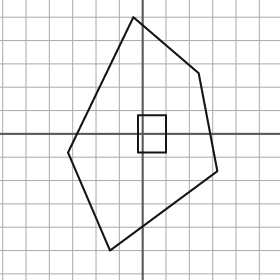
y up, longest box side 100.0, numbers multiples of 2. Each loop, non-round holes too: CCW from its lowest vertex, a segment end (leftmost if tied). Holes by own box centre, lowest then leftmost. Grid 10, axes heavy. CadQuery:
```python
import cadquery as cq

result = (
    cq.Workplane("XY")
    .moveTo(-14.0, -50.0)
    .lineTo(32.0, -16.0)
    .lineTo(24.0, 26.0)
    .lineTo(-4.0, 50.0)
    .lineTo(-32.0, -8.0)
    .close()
    .moveTo(-2.0, -8.0)
    .lineTo(10.0, -8.0)
    .lineTo(10.0, 8.0)
    .lineTo(-2.0, 8.0)
    .close()
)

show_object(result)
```